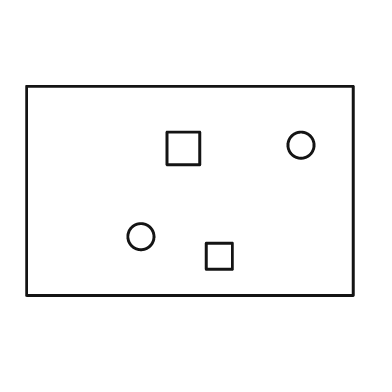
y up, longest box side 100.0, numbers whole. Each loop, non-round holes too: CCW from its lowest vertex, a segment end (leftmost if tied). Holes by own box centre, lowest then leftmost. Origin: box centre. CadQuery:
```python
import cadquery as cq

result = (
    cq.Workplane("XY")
    .moveTo(-50.0, -32.0)
    .lineTo(50.0, -32.0)
    .lineTo(50.0, 32.0)
    .lineTo(-50.0, 32.0)
    .close()
    .moveTo(5.0, -24.0)
    .lineTo(13.0, -24.0)
    .lineTo(13.0, -16.0)
    .lineTo(5.0, -16.0)
    .close()
    .moveTo(-15.0, -14.0)
    .circle(4.0)
    .moveTo(-7.0, 8.0)
    .lineTo(3.0, 8.0)
    .lineTo(3.0, 18.0)
    .lineTo(-7.0, 18.0)
    .close()
    .moveTo(34.0, 14.0)
    .circle(4.0)
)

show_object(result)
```